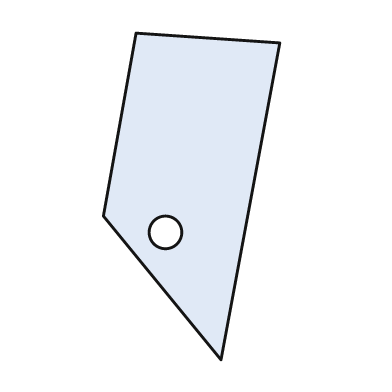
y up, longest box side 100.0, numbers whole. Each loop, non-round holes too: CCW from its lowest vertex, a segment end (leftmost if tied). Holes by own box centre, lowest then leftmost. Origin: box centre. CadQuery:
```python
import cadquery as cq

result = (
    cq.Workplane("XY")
    .moveTo(9.0, -50.0)
    .lineTo(27.0, 47.0)
    .lineTo(-17.0, 50.0)
    .lineTo(-27.0, -6.0)
    .close()
    .moveTo(-8.0, -11.0)
    .circle(5.0)
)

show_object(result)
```